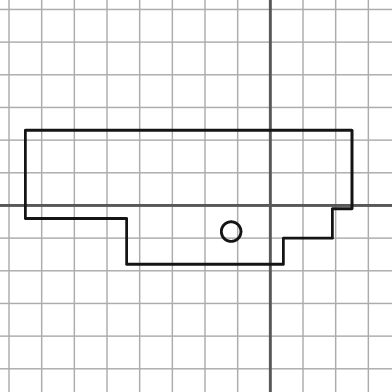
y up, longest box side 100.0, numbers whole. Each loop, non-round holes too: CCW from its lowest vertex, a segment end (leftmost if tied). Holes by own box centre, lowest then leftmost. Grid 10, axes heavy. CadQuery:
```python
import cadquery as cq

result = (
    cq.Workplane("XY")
    .moveTo(-44.0, -18.0)
    .lineTo(4.0, -18.0)
    .lineTo(4.0, -10.0)
    .lineTo(19.0, -10.0)
    .lineTo(19.0, -1.0)
    .lineTo(25.0, -1.0)
    .lineTo(25.0, 23.0)
    .lineTo(-75.0, 23.0)
    .lineTo(-75.0, -4.0)
    .lineTo(-44.0, -4.0)
    .close()
    .moveTo(-12.0, -8.0)
    .circle(3.0)
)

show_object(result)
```